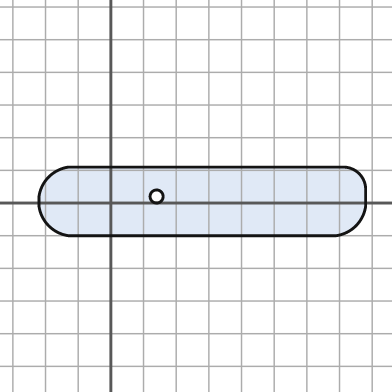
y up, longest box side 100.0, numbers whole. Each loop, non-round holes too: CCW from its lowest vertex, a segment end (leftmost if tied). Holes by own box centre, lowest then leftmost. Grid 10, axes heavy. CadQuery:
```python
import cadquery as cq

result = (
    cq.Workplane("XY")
    .moveTo(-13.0, -10.0)
    .lineTo(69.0, -10.0)
    .threePointArc((75.0, -7.0), (78.0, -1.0))
    .lineTo(78.0, 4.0)
    .threePointArc((76.0, 9.0), (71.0, 11.0))
    .lineTo(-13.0, 11.0)
    .threePointArc((-19.0, 8.0), (-22.0, 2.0))
    .lineTo(-22.0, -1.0)
    .threePointArc((-19.0, -7.0), (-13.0, -10.0))
    .close()
    .moveTo(14.0, 2.0)
    .circle(2.0)
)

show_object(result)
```